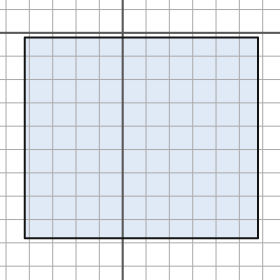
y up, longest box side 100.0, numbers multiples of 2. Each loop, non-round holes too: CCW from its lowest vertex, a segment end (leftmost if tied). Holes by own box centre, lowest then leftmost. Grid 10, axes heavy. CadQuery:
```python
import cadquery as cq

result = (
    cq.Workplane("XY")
    .moveTo(-42.0, -88.0)
    .lineTo(58.0, -88.0)
    .lineTo(58.0, -2.0)
    .lineTo(-42.0, -2.0)
    .close()
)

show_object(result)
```